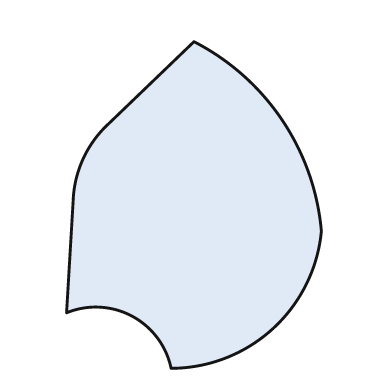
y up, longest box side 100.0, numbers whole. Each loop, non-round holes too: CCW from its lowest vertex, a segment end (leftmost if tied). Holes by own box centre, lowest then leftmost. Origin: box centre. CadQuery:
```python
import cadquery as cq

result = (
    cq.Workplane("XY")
    .moveTo(-7.0, -50.0)
    .threePointArc((24.0, -38.0), (39.0, -8.0))
    .threePointArc((27.0, 26.0), (0.0, 50.0))
    .lineTo(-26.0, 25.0)
    .threePointArc((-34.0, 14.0), (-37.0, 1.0))
    .lineTo(-39.0, -33.0)
    .threePointArc((-19.0, -34.0), (-7.0, -50.0))
    .close()
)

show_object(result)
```